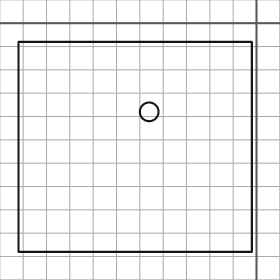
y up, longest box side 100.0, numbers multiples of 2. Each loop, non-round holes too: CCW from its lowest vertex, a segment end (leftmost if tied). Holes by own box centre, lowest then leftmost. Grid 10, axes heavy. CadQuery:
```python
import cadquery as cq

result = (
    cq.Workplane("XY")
    .moveTo(-102.0, -98.0)
    .lineTo(-2.0, -98.0)
    .lineTo(-2.0, -8.0)
    .lineTo(-102.0, -8.0)
    .close()
    .moveTo(-46.0, -38.0)
    .circle(4.0)
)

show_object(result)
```